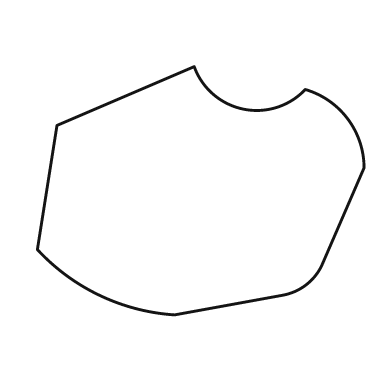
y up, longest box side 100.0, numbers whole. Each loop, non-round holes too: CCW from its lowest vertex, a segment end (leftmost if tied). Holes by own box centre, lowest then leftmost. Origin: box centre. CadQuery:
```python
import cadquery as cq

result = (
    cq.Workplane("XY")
    .moveTo(-8.0, -38.0)
    .lineTo(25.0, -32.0)
    .threePointArc((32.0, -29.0), (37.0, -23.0))
    .lineTo(50.0, 7.0)
    .threePointArc((45.0, 22.0), (32.0, 31.0))
    .threePointArc((13.0, 25.0), (-2.0, 38.0))
    .lineTo(-44.0, 20.0)
    .lineTo(-50.0, -18.0)
    .threePointArc((-31.0, -32.0), (-8.0, -38.0))
    .close()
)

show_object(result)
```